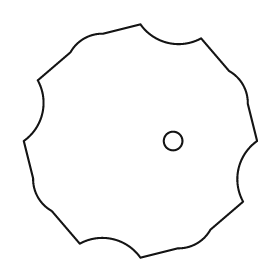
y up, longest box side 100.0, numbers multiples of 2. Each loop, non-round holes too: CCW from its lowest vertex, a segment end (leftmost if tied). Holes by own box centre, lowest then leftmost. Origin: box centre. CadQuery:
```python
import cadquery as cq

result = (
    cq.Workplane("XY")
    .moveTo(0.0, -50.0)
    .lineTo(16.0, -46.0)
    .threePointArc((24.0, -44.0), (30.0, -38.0))
    .lineTo(44.0, -26.0)
    .threePointArc((42.0, -12.0), (50.0, 0.0))
    .lineTo(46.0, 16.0)
    .threePointArc((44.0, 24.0), (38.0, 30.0))
    .lineTo(26.0, 44.0)
    .threePointArc((12.0, 42.0), (0.0, 50.0))
    .lineTo(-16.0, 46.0)
    .threePointArc((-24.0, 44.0), (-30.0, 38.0))
    .lineTo(-44.0, 26.0)
    .threePointArc((-42.0, 12.0), (-50.0, 0.0))
    .lineTo(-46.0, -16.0)
    .threePointArc((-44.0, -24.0), (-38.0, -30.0))
    .lineTo(-26.0, -44.0)
    .threePointArc((-12.0, -42.0), (0.0, -50.0))
    .close()
    .moveTo(14.0, 0.0)
    .circle(4.0)
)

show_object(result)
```